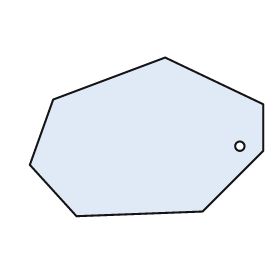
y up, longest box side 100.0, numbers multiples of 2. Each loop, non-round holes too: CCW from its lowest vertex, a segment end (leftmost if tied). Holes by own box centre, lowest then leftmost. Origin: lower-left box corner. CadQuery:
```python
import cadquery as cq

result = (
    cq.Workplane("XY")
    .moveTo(20.0, 0.0)
    .lineTo(74.0, 2.0)
    .lineTo(100.0, 28.0)
    .lineTo(100.0, 48.0)
    .lineTo(58.0, 68.0)
    .lineTo(10.0, 50.0)
    .lineTo(0.0, 22.0)
    .close()
    .moveTo(90.0, 30.0)
    .circle(2.0)
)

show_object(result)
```